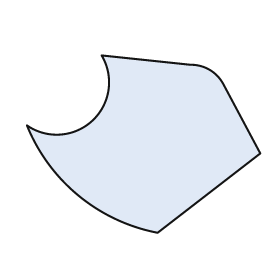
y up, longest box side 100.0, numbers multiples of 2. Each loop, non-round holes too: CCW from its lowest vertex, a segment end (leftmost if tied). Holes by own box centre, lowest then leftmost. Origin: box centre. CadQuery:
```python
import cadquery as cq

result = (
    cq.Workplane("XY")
    .moveTo(6.0, -38.0)
    .lineTo(50.0, -4.0)
    .lineTo(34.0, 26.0)
    .threePointArc((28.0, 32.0), (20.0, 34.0))
    .lineTo(-18.0, 38.0)
    .threePointArc((-22.0, 10.0), (-50.0, 8.0))
    .threePointArc((-28.0, -22.0), (6.0, -38.0))
    .close()
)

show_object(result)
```